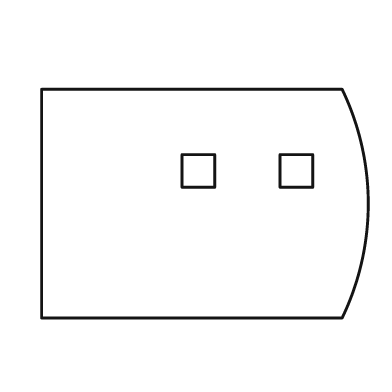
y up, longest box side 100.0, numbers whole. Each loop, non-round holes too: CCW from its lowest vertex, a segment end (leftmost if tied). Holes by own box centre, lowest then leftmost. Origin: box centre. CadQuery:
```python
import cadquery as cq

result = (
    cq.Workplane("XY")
    .moveTo(-50.0, -35.0)
    .lineTo(42.0, -35.0)
    .threePointArc((50.0, 0.0), (42.0, 35.0))
    .lineTo(-50.0, 35.0)
    .close()
    .moveTo(-7.0, 5.0)
    .lineTo(3.0, 5.0)
    .lineTo(3.0, 15.0)
    .lineTo(-7.0, 15.0)
    .close()
    .moveTo(23.0, 5.0)
    .lineTo(33.0, 5.0)
    .lineTo(33.0, 15.0)
    .lineTo(23.0, 15.0)
    .close()
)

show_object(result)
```